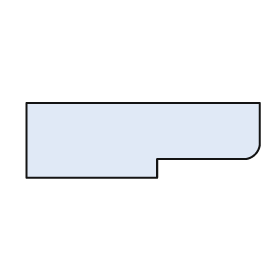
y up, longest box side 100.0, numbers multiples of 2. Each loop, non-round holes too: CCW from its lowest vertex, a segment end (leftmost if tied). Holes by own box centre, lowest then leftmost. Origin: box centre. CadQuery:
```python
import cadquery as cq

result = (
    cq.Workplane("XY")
    .moveTo(-50.0, -16.0)
    .lineTo(6.0, -16.0)
    .lineTo(6.0, -8.0)
    .lineTo(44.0, -8.0)
    .threePointArc((48.0, -6.0), (50.0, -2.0))
    .lineTo(50.0, 16.0)
    .lineTo(-50.0, 16.0)
    .close()
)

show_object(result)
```